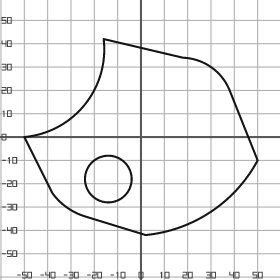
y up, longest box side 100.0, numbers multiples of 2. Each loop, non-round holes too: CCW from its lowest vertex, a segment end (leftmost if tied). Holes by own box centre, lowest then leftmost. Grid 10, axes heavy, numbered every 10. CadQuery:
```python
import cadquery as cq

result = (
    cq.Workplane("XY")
    .moveTo(2.0, -42.0)
    .threePointArc((30.0, -32.0), (50.0, -10.0))
    .lineTo(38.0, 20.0)
    .threePointArc((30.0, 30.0), (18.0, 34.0))
    .lineTo(-16.0, 42.0)
    .threePointArc((-24.0, 14.0), (-50.0, 0.0))
    .lineTo(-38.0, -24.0)
    .threePointArc((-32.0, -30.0), (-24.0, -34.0))
    .close()
    .moveTo(-14.0, -18.0)
    .circle(10.0)
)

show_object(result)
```